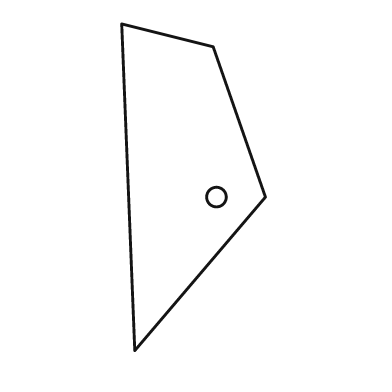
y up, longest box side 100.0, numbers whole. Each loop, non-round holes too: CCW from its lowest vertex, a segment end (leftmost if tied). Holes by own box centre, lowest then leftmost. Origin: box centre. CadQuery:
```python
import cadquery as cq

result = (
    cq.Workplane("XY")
    .moveTo(-18.0, -50.0)
    .lineTo(22.0, -3.0)
    .lineTo(6.0, 43.0)
    .lineTo(-22.0, 50.0)
    .close()
    .moveTo(7.0, -3.0)
    .circle(3.0)
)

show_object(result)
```